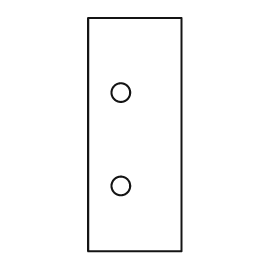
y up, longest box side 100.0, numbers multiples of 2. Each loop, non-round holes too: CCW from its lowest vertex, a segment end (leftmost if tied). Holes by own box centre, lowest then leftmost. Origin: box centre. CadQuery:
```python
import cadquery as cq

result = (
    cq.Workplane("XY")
    .moveTo(-20.0, -50.0)
    .lineTo(20.0, -50.0)
    .lineTo(20.0, 50.0)
    .lineTo(-20.0, 50.0)
    .close()
    .moveTo(-6.0, -22.0)
    .circle(4.0)
    .moveTo(-6.0, 18.0)
    .circle(4.0)
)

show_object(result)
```